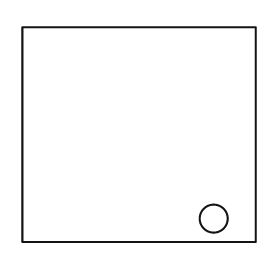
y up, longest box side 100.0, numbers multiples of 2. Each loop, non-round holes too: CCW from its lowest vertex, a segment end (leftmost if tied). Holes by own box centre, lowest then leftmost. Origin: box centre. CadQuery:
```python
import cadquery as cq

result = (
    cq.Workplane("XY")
    .moveTo(-50.0, -46.0)
    .lineTo(50.0, -46.0)
    .lineTo(50.0, 46.0)
    .lineTo(-50.0, 46.0)
    .close()
    .moveTo(32.0, -36.0)
    .circle(6.0)
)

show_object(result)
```